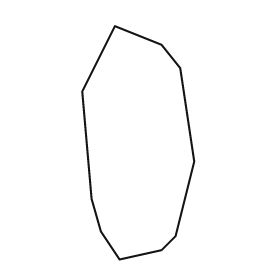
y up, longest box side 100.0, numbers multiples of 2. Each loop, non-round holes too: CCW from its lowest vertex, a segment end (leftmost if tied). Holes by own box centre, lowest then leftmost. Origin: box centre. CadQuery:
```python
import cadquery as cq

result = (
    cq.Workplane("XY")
    .moveTo(-8.0, -50.0)
    .lineTo(10.0, -46.0)
    .lineTo(16.0, -40.0)
    .lineTo(24.0, -8.0)
    .lineTo(18.0, 32.0)
    .lineTo(10.0, 42.0)
    .lineTo(-10.0, 50.0)
    .lineTo(-24.0, 22.0)
    .lineTo(-20.0, -24.0)
    .lineTo(-16.0, -38.0)
    .close()
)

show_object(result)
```